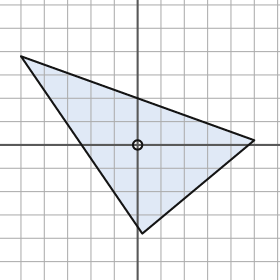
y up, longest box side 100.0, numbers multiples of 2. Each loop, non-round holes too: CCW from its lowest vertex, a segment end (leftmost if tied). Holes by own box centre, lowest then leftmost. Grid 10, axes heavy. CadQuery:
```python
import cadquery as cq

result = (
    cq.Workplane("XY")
    .moveTo(2.0, -38.0)
    .lineTo(50.0, 2.0)
    .lineTo(-50.0, 38.0)
    .close()
    .moveTo(0.0, 0.0)
    .circle(2.0)
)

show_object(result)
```